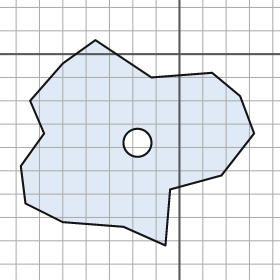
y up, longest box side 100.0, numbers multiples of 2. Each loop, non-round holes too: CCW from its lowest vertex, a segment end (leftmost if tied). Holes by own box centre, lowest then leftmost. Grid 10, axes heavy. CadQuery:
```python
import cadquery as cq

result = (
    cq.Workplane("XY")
    .moveTo(-6.0, -82.0)
    .lineTo(-4.0, -58.0)
    .lineTo(18.0, -52.0)
    .lineTo(32.0, -34.0)
    .lineTo(26.0, -18.0)
    .lineTo(14.0, -8.0)
    .lineTo(-12.0, -10.0)
    .lineTo(-36.0, 6.0)
    .lineTo(-50.0, -4.0)
    .lineTo(-64.0, -20.0)
    .lineTo(-58.0, -34.0)
    .lineTo(-68.0, -48.0)
    .lineTo(-66.0, -64.0)
    .lineTo(-50.0, -72.0)
    .lineTo(-24.0, -74.0)
    .close()
    .moveTo(-18.0, -38.0)
    .circle(6.0)
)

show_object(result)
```